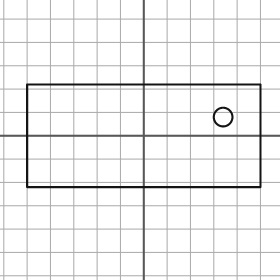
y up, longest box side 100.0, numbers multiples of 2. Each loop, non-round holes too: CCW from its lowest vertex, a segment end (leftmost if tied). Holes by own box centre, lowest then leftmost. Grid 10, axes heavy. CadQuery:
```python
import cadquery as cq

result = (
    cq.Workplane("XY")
    .moveTo(-50.0, -22.0)
    .lineTo(50.0, -22.0)
    .lineTo(50.0, 22.0)
    .lineTo(-50.0, 22.0)
    .close()
    .moveTo(34.0, 8.0)
    .circle(4.0)
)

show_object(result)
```